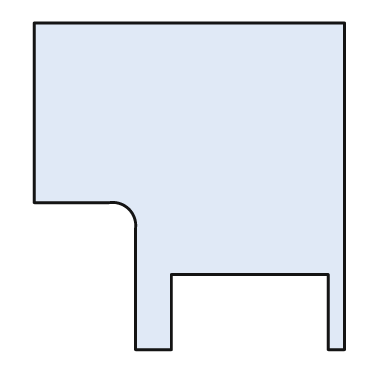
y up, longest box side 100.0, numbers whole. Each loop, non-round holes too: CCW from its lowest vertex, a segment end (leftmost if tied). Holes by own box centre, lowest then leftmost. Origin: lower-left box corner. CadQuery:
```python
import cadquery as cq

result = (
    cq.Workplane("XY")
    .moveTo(31.0, 0.0)
    .lineTo(42.0, 0.0)
    .lineTo(42.0, 23.0)
    .lineTo(90.0, 23.0)
    .lineTo(90.0, 0.0)
    .lineTo(95.0, 0.0)
    .lineTo(95.0, 100.0)
    .lineTo(0.0, 100.0)
    .lineTo(0.0, 45.0)
    .lineTo(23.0, 45.0)
    .threePointArc((29.0, 43.0), (31.0, 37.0))
    .close()
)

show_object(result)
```